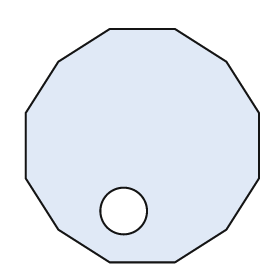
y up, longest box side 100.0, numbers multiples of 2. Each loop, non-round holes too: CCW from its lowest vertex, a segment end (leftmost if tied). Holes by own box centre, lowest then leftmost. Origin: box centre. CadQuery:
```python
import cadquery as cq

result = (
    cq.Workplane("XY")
    .moveTo(-14.0, -50.0)
    .lineTo(14.0, -50.0)
    .lineTo(36.0, -36.0)
    .lineTo(50.0, -14.0)
    .lineTo(50.0, 14.0)
    .lineTo(36.0, 36.0)
    .lineTo(14.0, 50.0)
    .lineTo(-14.0, 50.0)
    .lineTo(-36.0, 36.0)
    .lineTo(-50.0, 14.0)
    .lineTo(-50.0, -14.0)
    .lineTo(-36.0, -36.0)
    .close()
    .moveTo(-8.0, -28.0)
    .circle(10.0)
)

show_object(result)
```